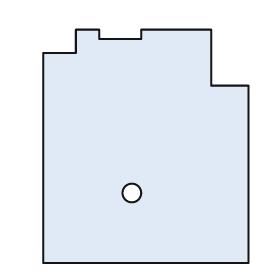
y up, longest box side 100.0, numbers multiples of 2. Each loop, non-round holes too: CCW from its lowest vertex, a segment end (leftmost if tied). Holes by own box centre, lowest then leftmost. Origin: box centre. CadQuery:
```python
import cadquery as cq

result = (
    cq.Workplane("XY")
    .moveTo(-44.0, -50.0)
    .lineTo(44.0, -50.0)
    .lineTo(44.0, 26.0)
    .lineTo(28.0, 26.0)
    .lineTo(28.0, 50.0)
    .lineTo(-2.0, 50.0)
    .lineTo(-2.0, 46.0)
    .lineTo(-20.0, 46.0)
    .lineTo(-20.0, 50.0)
    .lineTo(-30.0, 50.0)
    .lineTo(-30.0, 40.0)
    .lineTo(-44.0, 40.0)
    .close()
    .moveTo(-6.0, -20.0)
    .circle(4.0)
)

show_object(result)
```